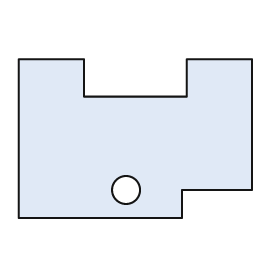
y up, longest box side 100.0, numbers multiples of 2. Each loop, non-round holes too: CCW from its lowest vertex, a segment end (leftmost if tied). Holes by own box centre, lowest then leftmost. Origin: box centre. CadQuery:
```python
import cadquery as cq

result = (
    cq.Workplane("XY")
    .moveTo(-50.0, -34.0)
    .lineTo(20.0, -34.0)
    .lineTo(20.0, -22.0)
    .lineTo(50.0, -22.0)
    .lineTo(50.0, 34.0)
    .lineTo(22.0, 34.0)
    .lineTo(22.0, 18.0)
    .lineTo(-22.0, 18.0)
    .lineTo(-22.0, 34.0)
    .lineTo(-50.0, 34.0)
    .close()
    .moveTo(-4.0, -22.0)
    .circle(6.0)
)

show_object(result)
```